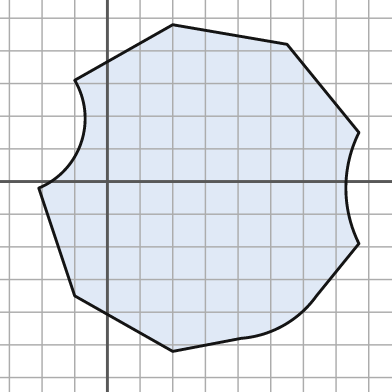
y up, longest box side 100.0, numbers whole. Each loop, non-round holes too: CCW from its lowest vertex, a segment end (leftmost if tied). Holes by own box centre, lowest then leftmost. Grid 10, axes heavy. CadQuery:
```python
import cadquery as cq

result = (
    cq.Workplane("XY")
    .moveTo(20.0, -52.0)
    .lineTo(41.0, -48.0)
    .threePointArc((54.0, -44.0), (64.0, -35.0))
    .lineTo(77.0, -19.0)
    .threePointArc((73.0, -2.0), (77.0, 15.0))
    .lineTo(55.0, 42.0)
    .lineTo(20.0, 48.0)
    .lineTo(-10.0, 31.0)
    .threePointArc((-8.0, 12.0), (-21.0, -2.0))
    .lineTo(-10.0, -35.0)
    .close()
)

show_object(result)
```